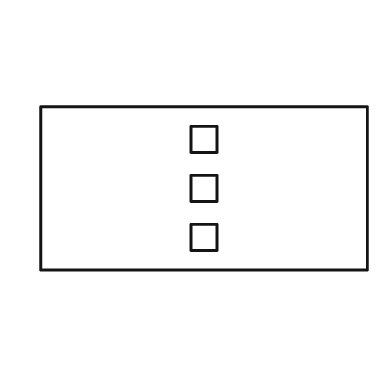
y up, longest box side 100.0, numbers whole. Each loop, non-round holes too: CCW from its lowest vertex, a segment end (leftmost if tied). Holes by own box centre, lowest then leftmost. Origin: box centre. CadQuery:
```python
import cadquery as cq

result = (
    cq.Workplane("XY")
    .moveTo(-50.0, -25.0)
    .lineTo(50.0, -25.0)
    .lineTo(50.0, 25.0)
    .lineTo(-50.0, 25.0)
    .close()
    .moveTo(-4.0, -19.0)
    .lineTo(4.0, -19.0)
    .lineTo(4.0, -11.0)
    .lineTo(-4.0, -11.0)
    .close()
    .moveTo(-4.0, -4.0)
    .lineTo(4.0, -4.0)
    .lineTo(4.0, 4.0)
    .lineTo(-4.0, 4.0)
    .close()
    .moveTo(-4.0, 11.0)
    .lineTo(4.0, 11.0)
    .lineTo(4.0, 19.0)
    .lineTo(-4.0, 19.0)
    .close()
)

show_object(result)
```